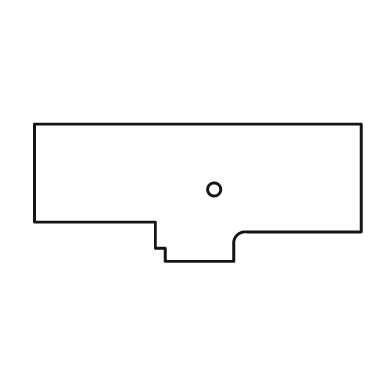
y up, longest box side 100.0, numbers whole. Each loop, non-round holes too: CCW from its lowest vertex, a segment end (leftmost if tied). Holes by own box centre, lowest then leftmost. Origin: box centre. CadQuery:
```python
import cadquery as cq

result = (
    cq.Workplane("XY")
    .moveTo(-10.0, -21.0)
    .lineTo(11.0, -21.0)
    .lineTo(11.0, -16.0)
    .threePointArc((12.0, -13.0), (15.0, -12.0))
    .lineTo(50.0, -12.0)
    .lineTo(50.0, 21.0)
    .lineTo(-50.0, 21.0)
    .lineTo(-50.0, -9.0)
    .lineTo(-13.0, -9.0)
    .lineTo(-13.0, -17.0)
    .lineTo(-10.0, -17.0)
    .close()
    .moveTo(5.0, 1.0)
    .circle(2.0)
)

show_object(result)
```